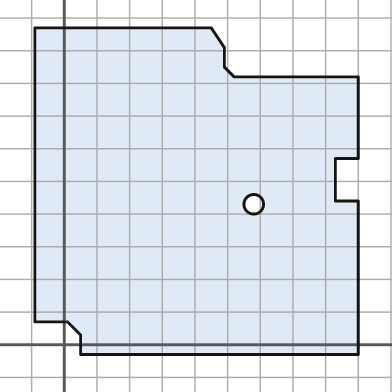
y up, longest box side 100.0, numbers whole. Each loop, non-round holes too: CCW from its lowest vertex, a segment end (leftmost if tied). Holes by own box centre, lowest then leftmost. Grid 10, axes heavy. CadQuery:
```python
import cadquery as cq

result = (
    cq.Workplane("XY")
    .moveTo(5.0, -3.0)
    .lineTo(90.0, -3.0)
    .lineTo(90.0, 44.0)
    .lineTo(83.0, 44.0)
    .lineTo(83.0, 57.0)
    .lineTo(90.0, 57.0)
    .lineTo(90.0, 82.0)
    .lineTo(52.0, 82.0)
    .lineTo(49.0, 85.0)
    .lineTo(49.0, 91.0)
    .lineTo(45.0, 97.0)
    .lineTo(-9.0, 97.0)
    .lineTo(-9.0, 7.0)
    .lineTo(1.0, 7.0)
    .lineTo(5.0, 3.0)
    .close()
    .moveTo(58.0, 43.0)
    .circle(3.0)
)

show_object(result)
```